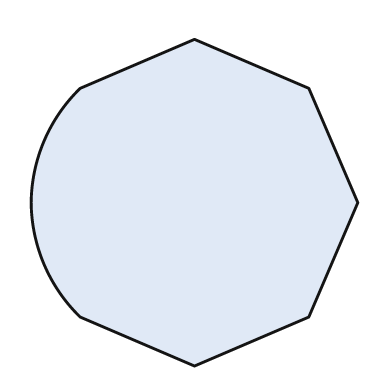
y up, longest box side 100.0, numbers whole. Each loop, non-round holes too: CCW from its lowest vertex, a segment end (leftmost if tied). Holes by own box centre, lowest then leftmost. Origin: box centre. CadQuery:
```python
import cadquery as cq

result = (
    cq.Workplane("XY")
    .moveTo(0.0, -50.0)
    .lineTo(35.0, -35.0)
    .lineTo(50.0, 0.0)
    .lineTo(35.0, 35.0)
    .lineTo(0.0, 50.0)
    .lineTo(-35.0, 35.0)
    .threePointArc((-46.0, 19.0), (-50.0, 0.0))
    .threePointArc((-46.0, -19.0), (-35.0, -35.0))
    .close()
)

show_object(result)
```